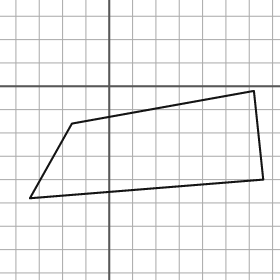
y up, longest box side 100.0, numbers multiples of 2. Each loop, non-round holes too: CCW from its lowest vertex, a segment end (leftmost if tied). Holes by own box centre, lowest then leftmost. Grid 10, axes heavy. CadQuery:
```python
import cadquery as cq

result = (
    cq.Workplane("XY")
    .moveTo(-34.0, -48.0)
    .lineTo(66.0, -40.0)
    .lineTo(62.0, -2.0)
    .lineTo(-16.0, -16.0)
    .close()
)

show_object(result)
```